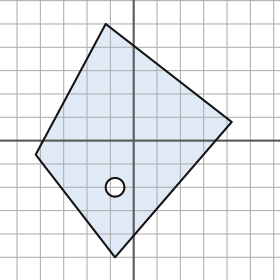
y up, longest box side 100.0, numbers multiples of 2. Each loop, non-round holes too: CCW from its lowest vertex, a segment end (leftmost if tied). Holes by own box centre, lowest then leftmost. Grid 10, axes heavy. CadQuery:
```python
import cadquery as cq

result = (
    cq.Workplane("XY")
    .moveTo(-8.0, -50.0)
    .lineTo(42.0, 8.0)
    .lineTo(-12.0, 50.0)
    .lineTo(-42.0, -6.0)
    .close()
    .moveTo(-8.0, -20.0)
    .circle(4.0)
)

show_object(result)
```